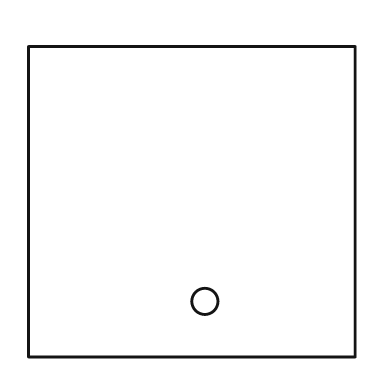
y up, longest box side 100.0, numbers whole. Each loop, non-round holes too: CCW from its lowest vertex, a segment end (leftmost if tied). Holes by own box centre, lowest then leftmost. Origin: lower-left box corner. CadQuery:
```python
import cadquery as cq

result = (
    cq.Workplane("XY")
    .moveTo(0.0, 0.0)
    .lineTo(100.0, 0.0)
    .lineTo(100.0, 95.0)
    .lineTo(0.0, 95.0)
    .close()
    .moveTo(54.0, 17.0)
    .circle(4.0)
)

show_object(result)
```